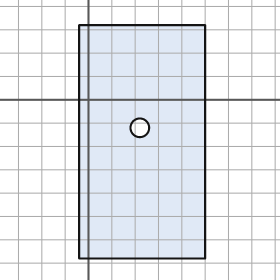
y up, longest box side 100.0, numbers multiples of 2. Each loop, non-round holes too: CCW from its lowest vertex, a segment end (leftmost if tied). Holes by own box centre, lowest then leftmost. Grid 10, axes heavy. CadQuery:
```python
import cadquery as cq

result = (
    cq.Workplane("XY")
    .moveTo(-4.0, -68.0)
    .lineTo(50.0, -68.0)
    .lineTo(50.0, 32.0)
    .lineTo(-4.0, 32.0)
    .close()
    .moveTo(22.0, -12.0)
    .circle(4.0)
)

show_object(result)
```